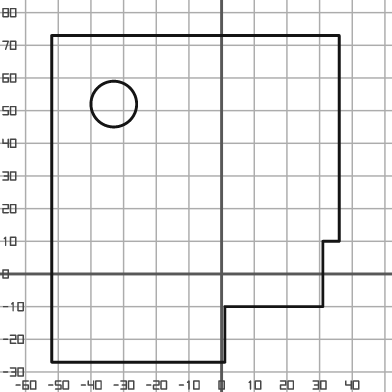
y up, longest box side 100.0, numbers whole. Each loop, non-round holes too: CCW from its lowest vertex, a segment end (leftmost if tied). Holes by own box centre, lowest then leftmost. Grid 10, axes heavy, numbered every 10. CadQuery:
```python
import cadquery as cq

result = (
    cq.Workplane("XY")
    .moveTo(-52.0, -27.0)
    .lineTo(1.0, -27.0)
    .lineTo(1.0, -10.0)
    .lineTo(31.0, -10.0)
    .lineTo(31.0, 10.0)
    .lineTo(36.0, 10.0)
    .lineTo(36.0, 73.0)
    .lineTo(-52.0, 73.0)
    .close()
    .moveTo(-33.0, 52.0)
    .circle(7.0)
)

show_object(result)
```